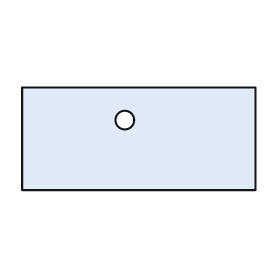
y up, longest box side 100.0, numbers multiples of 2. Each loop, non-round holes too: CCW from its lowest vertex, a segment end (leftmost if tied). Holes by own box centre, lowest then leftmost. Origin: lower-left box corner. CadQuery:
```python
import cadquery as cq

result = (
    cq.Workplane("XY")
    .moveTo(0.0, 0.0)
    .lineTo(100.0, 0.0)
    .lineTo(100.0, 44.0)
    .lineTo(0.0, 44.0)
    .close()
    .moveTo(44.0, 30.0)
    .circle(4.0)
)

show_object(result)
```